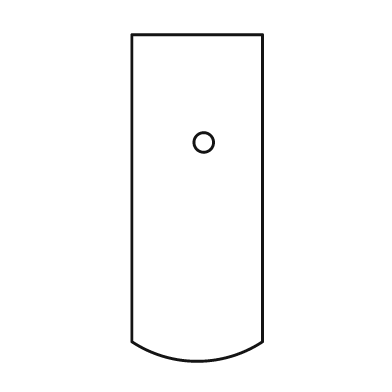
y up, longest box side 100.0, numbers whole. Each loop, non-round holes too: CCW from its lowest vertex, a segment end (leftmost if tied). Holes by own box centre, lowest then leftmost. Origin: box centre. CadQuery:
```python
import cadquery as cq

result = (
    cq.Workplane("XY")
    .moveTo(-20.0, -44.0)
    .threePointArc((0.0, -50.0), (20.0, -44.0))
    .lineTo(20.0, 50.0)
    .lineTo(-20.0, 50.0)
    .close()
    .moveTo(2.0, 17.0)
    .circle(3.0)
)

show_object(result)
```